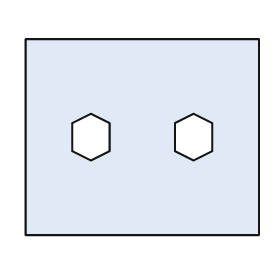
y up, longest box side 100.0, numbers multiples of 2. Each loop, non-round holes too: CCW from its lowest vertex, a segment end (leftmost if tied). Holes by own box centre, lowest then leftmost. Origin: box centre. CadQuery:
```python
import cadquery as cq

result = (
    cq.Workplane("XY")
    .moveTo(-50.0, -42.0)
    .lineTo(50.0, -42.0)
    .lineTo(50.0, 42.0)
    .lineTo(-50.0, 42.0)
    .close()
    .moveTo(-22.0, -10.0)
    .lineTo(-14.0, -6.0)
    .lineTo(-14.0, 6.0)
    .lineTo(-22.0, 10.0)
    .lineTo(-30.0, 6.0)
    .lineTo(-30.0, -6.0)
    .close()
    .moveTo(22.0, -10.0)
    .lineTo(30.0, -6.0)
    .lineTo(30.0, 6.0)
    .lineTo(22.0, 10.0)
    .lineTo(14.0, 6.0)
    .lineTo(14.0, -6.0)
    .close()
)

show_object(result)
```